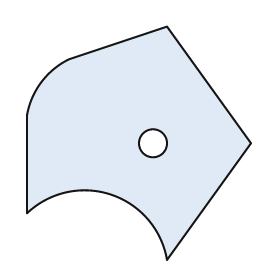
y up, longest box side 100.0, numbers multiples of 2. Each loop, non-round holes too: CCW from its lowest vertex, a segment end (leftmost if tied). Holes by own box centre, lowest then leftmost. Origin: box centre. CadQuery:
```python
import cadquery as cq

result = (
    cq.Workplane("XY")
    .moveTo(12.0, -50.0)
    .lineTo(48.0, 0.0)
    .lineTo(12.0, 50.0)
    .lineTo(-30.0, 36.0)
    .threePointArc((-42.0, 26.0), (-48.0, 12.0))
    .lineTo(-48.0, -30.0)
    .threePointArc((-12.0, -22.0), (12.0, -50.0))
    .close()
    .moveTo(6.0, 0.0)
    .circle(6.0)
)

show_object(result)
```